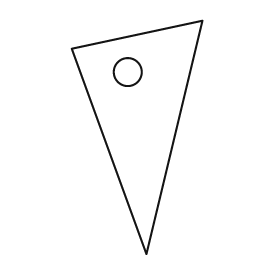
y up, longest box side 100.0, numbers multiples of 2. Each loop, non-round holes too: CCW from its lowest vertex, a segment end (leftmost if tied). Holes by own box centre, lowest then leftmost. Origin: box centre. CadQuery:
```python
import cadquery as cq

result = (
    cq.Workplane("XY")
    .moveTo(4.0, -50.0)
    .lineTo(28.0, 50.0)
    .lineTo(-28.0, 38.0)
    .close()
    .moveTo(-4.0, 28.0)
    .circle(6.0)
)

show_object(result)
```